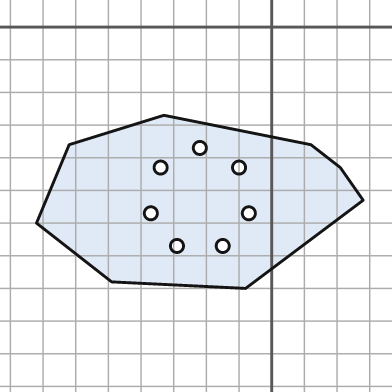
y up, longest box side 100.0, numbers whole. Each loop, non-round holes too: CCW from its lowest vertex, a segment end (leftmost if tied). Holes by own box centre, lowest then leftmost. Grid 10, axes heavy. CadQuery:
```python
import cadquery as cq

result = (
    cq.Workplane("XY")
    .moveTo(-8.0, -80.0)
    .lineTo(28.0, -53.0)
    .lineTo(21.0, -43.0)
    .lineTo(12.0, -36.0)
    .lineTo(-33.0, -27.0)
    .lineTo(-62.0, -36.0)
    .lineTo(-72.0, -60.0)
    .lineTo(-49.0, -78.0)
    .close()
    .moveTo(-29.0, -67.0)
    .circle(2.0)
    .moveTo(-15.0, -67.0)
    .circle(2.0)
    .moveTo(-37.0, -57.0)
    .circle(2.0)
    .moveTo(-7.0, -57.0)
    .circle(2.0)
    .moveTo(-34.0, -43.0)
    .circle(2.0)
    .moveTo(-10.0, -43.0)
    .circle(2.0)
    .moveTo(-22.0, -37.0)
    .circle(2.0)
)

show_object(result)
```